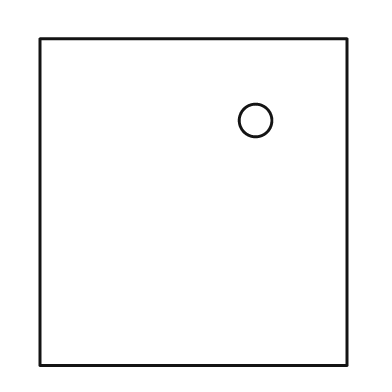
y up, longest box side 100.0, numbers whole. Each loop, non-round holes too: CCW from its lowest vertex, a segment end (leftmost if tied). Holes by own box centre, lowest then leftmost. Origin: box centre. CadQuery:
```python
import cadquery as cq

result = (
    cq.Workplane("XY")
    .moveTo(-47.0, -50.0)
    .lineTo(47.0, -50.0)
    .lineTo(47.0, 50.0)
    .lineTo(-47.0, 50.0)
    .close()
    .moveTo(19.0, 25.0)
    .circle(5.0)
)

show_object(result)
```